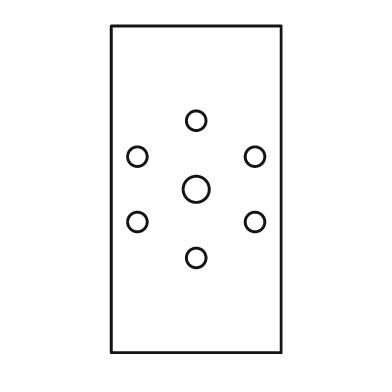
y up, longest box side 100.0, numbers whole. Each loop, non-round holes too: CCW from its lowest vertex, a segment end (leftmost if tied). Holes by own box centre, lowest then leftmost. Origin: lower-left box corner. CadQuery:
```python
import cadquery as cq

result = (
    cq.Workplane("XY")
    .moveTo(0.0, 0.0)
    .lineTo(52.0, 0.0)
    .lineTo(52.0, 100.0)
    .lineTo(0.0, 100.0)
    .close()
    .moveTo(26.0, 29.0)
    .circle(3.0)
    .moveTo(8.0, 40.0)
    .circle(3.0)
    .moveTo(44.0, 40.0)
    .circle(3.0)
    .moveTo(26.0, 50.0)
    .circle(4.0)
    .moveTo(8.0, 60.0)
    .circle(3.0)
    .moveTo(44.0, 60.0)
    .circle(3.0)
    .moveTo(26.0, 71.0)
    .circle(3.0)
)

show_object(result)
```